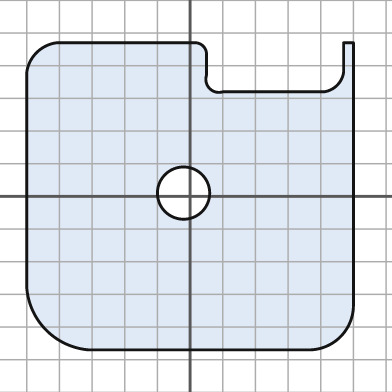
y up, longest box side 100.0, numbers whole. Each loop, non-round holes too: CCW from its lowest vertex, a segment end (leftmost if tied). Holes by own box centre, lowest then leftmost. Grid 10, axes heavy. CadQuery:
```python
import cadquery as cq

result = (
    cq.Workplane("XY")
    .moveTo(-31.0, -47.0)
    .lineTo(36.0, -47.0)
    .threePointArc((46.0, -43.0), (50.0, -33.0))
    .lineTo(50.0, 47.0)
    .lineTo(47.0, 47.0)
    .lineTo(47.0, 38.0)
    .threePointArc((45.0, 34.0), (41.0, 32.0))
    .lineTo(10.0, 32.0)
    .threePointArc((6.0, 33.0), (5.0, 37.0))
    .lineTo(5.0, 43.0)
    .threePointArc((4.0, 46.0), (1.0, 47.0))
    .lineTo(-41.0, 47.0)
    .threePointArc((-47.0, 44.0), (-50.0, 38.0))
    .lineTo(-50.0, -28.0)
    .threePointArc((-44.0, -41.0), (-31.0, -47.0))
    .close()
    .moveTo(-2.0, 1.0)
    .circle(8.0)
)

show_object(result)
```